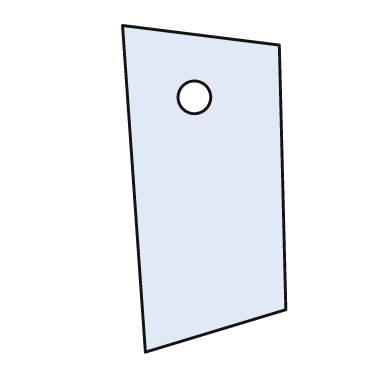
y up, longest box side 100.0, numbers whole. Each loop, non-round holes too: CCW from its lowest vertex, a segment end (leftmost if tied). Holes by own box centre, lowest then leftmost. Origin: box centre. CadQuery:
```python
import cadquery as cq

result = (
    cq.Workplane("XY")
    .moveTo(-18.0, -50.0)
    .lineTo(25.0, -37.0)
    .lineTo(23.0, 44.0)
    .lineTo(-25.0, 50.0)
    .close()
    .moveTo(-3.0, 28.0)
    .circle(5.0)
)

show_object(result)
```